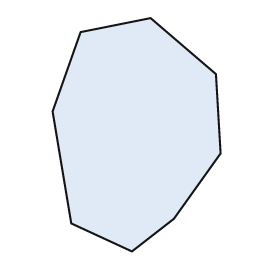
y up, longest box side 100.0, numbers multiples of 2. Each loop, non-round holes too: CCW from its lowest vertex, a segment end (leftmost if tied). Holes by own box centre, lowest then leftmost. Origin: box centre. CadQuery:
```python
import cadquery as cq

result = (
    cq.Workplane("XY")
    .moveTo(-2.0, -50.0)
    .lineTo(16.0, -36.0)
    .lineTo(36.0, -8.0)
    .lineTo(34.0, 26.0)
    .lineTo(6.0, 50.0)
    .lineTo(-24.0, 44.0)
    .lineTo(-36.0, 10.0)
    .lineTo(-28.0, -38.0)
    .close()
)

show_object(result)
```